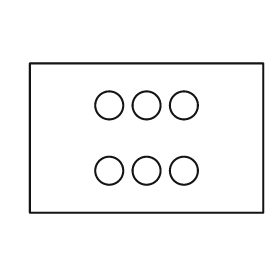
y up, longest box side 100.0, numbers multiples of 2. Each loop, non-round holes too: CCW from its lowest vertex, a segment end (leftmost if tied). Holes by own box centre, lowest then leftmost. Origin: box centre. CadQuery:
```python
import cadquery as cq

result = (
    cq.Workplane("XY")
    .moveTo(-50.0, -32.0)
    .lineTo(50.0, -32.0)
    .lineTo(50.0, 32.0)
    .lineTo(-50.0, 32.0)
    .close()
    .moveTo(-16.0, -14.0)
    .circle(6.0)
    .moveTo(0.0, -14.0)
    .circle(6.0)
    .moveTo(16.0, -14.0)
    .circle(6.0)
    .moveTo(-16.0, 14.0)
    .circle(6.0)
    .moveTo(0.0, 14.0)
    .circle(6.0)
    .moveTo(16.0, 14.0)
    .circle(6.0)
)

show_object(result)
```